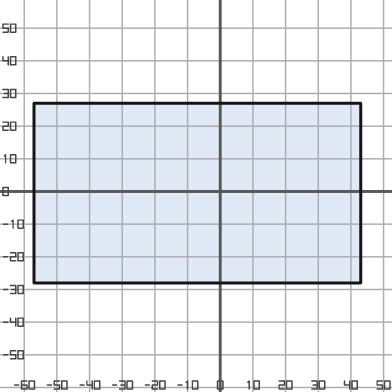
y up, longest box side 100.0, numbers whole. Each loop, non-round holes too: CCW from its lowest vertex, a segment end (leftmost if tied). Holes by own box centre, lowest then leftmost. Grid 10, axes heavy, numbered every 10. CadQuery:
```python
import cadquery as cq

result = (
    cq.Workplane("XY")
    .moveTo(-57.0, -28.0)
    .lineTo(43.0, -28.0)
    .lineTo(43.0, 27.0)
    .lineTo(-57.0, 27.0)
    .close()
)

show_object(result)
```